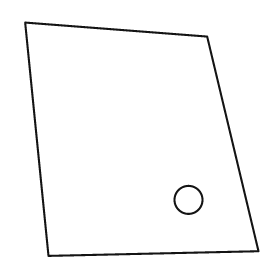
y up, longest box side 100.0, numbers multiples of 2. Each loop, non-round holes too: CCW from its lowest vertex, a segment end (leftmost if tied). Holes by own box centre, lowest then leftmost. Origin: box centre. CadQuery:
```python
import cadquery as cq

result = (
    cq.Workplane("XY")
    .moveTo(-40.0, -50.0)
    .lineTo(50.0, -48.0)
    .lineTo(28.0, 44.0)
    .lineTo(-50.0, 50.0)
    .close()
    .moveTo(20.0, -26.0)
    .circle(6.0)
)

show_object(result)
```